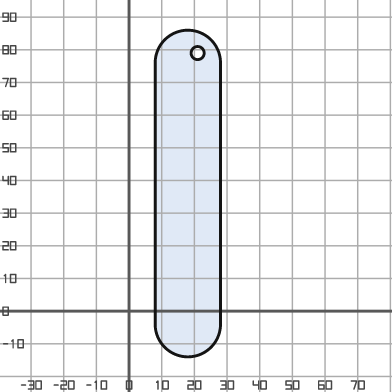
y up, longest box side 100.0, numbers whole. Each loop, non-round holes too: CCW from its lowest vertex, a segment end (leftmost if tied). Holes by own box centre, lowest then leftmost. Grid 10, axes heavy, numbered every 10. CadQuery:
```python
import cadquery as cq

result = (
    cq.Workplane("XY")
    .moveTo(8.0, -4.0)
    .threePointArc((18.0, -14.0), (28.0, -4.0))
    .lineTo(28.0, 76.0)
    .threePointArc((18.0, 86.0), (8.0, 76.0))
    .close()
    .moveTo(21.0, 79.0)
    .circle(2.0)
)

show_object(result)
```